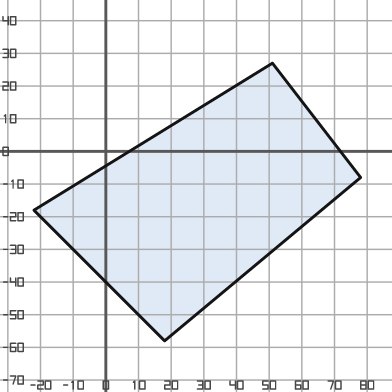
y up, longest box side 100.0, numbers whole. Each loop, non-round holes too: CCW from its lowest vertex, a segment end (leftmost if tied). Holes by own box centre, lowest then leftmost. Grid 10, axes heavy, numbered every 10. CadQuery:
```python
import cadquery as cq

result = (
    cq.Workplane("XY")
    .moveTo(18.0, -58.0)
    .lineTo(78.0, -8.0)
    .lineTo(51.0, 27.0)
    .lineTo(-22.0, -18.0)
    .close()
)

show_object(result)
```